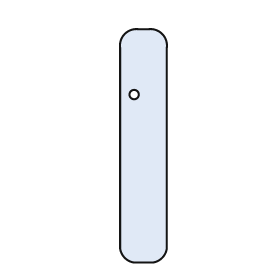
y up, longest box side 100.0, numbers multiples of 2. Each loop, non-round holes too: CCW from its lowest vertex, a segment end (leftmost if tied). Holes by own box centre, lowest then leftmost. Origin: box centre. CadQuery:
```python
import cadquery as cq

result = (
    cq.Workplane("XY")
    .moveTo(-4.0, -50.0)
    .lineTo(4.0, -50.0)
    .threePointArc((8.0, -48.0), (10.0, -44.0))
    .lineTo(10.0, 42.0)
    .threePointArc((8.0, 48.0), (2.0, 50.0))
    .lineTo(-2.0, 50.0)
    .threePointArc((-8.0, 48.0), (-10.0, 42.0))
    .lineTo(-10.0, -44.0)
    .threePointArc((-8.0, -48.0), (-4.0, -50.0))
    .close()
    .moveTo(-4.0, 22.0)
    .circle(2.0)
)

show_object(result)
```